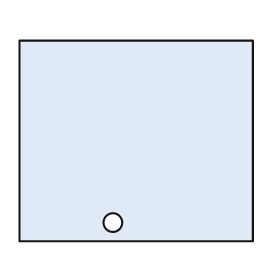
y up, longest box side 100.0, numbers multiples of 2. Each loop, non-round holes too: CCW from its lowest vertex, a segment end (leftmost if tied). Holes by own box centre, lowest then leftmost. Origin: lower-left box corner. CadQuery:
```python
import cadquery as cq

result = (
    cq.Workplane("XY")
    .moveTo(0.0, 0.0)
    .lineTo(100.0, 0.0)
    .lineTo(100.0, 86.0)
    .lineTo(0.0, 86.0)
    .close()
    .moveTo(40.0, 8.0)
    .circle(4.0)
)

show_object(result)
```